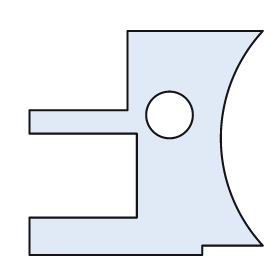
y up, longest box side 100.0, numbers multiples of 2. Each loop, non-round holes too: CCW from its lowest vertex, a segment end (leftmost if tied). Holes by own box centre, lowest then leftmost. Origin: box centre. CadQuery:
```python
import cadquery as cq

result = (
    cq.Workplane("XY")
    .moveTo(-50.0, -48.0)
    .lineTo(24.0, -48.0)
    .lineTo(24.0, -44.0)
    .lineTo(50.0, -44.0)
    .threePointArc((32.0, 2.0), (50.0, 48.0))
    .lineTo(-8.0, 48.0)
    .lineTo(-8.0, 14.0)
    .lineTo(-50.0, 14.0)
    .lineTo(-50.0, 4.0)
    .lineTo(-4.0, 4.0)
    .lineTo(-4.0, -32.0)
    .lineTo(-50.0, -32.0)
    .close()
    .moveTo(10.0, 12.0)
    .circle(10.0)
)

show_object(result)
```